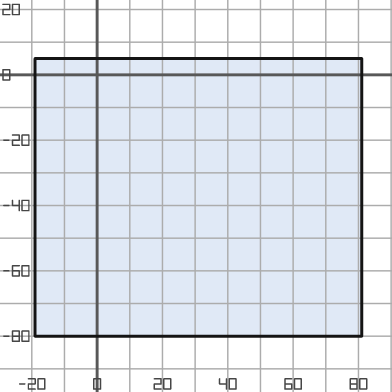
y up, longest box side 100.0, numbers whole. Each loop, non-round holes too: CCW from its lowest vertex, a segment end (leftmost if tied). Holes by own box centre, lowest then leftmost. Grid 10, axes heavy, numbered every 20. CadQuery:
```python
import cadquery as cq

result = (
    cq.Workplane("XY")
    .moveTo(-19.0, -80.0)
    .lineTo(81.0, -80.0)
    .lineTo(81.0, 5.0)
    .lineTo(-19.0, 5.0)
    .close()
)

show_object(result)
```